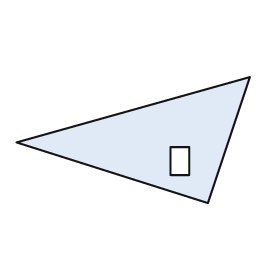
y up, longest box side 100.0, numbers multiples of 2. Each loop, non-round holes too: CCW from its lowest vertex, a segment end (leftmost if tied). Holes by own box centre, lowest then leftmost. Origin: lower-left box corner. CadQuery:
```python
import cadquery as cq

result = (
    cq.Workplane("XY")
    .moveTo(82.0, 0.0)
    .lineTo(100.0, 54.0)
    .lineTo(0.0, 26.0)
    .close()
    .moveTo(66.0, 12.0)
    .lineTo(74.0, 12.0)
    .lineTo(74.0, 24.0)
    .lineTo(66.0, 24.0)
    .close()
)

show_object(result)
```